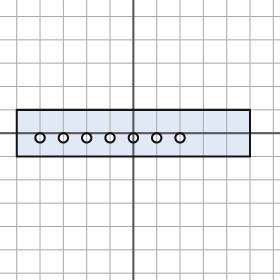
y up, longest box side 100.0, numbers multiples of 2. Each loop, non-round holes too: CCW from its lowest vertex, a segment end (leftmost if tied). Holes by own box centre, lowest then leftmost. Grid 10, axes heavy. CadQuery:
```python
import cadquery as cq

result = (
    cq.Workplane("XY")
    .moveTo(-50.0, -10.0)
    .lineTo(50.0, -10.0)
    .lineTo(50.0, 10.0)
    .lineTo(-50.0, 10.0)
    .close()
    .moveTo(-40.0, -2.0)
    .circle(2.0)
    .moveTo(-30.0, -2.0)
    .circle(2.0)
    .moveTo(-20.0, -2.0)
    .circle(2.0)
    .moveTo(-10.0, -2.0)
    .circle(2.0)
    .moveTo(0.0, -2.0)
    .circle(2.0)
    .moveTo(10.0, -2.0)
    .circle(2.0)
    .moveTo(20.0, -2.0)
    .circle(2.0)
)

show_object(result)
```